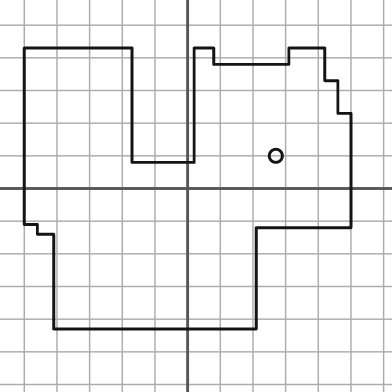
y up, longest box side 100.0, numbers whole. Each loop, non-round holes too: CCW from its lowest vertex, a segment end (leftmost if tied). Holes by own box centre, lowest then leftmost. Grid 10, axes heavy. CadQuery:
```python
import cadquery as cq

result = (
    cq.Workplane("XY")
    .moveTo(-41.0, -43.0)
    .lineTo(21.0, -43.0)
    .lineTo(21.0, -12.0)
    .lineTo(50.0, -12.0)
    .lineTo(50.0, 23.0)
    .lineTo(46.0, 23.0)
    .lineTo(46.0, 33.0)
    .lineTo(42.0, 33.0)
    .lineTo(42.0, 43.0)
    .lineTo(31.0, 43.0)
    .lineTo(31.0, 38.0)
    .lineTo(8.0, 38.0)
    .lineTo(8.0, 43.0)
    .lineTo(2.0, 43.0)
    .lineTo(2.0, 8.0)
    .lineTo(-17.0, 8.0)
    .lineTo(-17.0, 43.0)
    .lineTo(-50.0, 43.0)
    .lineTo(-50.0, -11.0)
    .lineTo(-46.0, -11.0)
    .lineTo(-46.0, -14.0)
    .lineTo(-41.0, -14.0)
    .close()
    .moveTo(27.0, 10.0)
    .circle(2.0)
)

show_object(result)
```